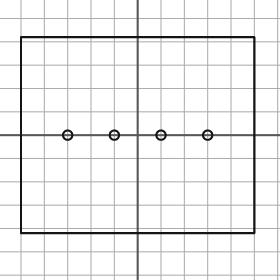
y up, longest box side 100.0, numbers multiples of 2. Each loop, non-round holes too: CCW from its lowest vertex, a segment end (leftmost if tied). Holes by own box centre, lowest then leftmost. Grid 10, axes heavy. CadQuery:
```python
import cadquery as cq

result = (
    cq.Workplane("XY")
    .moveTo(-50.0, -42.0)
    .lineTo(50.0, -42.0)
    .lineTo(50.0, 42.0)
    .lineTo(-50.0, 42.0)
    .close()
    .moveTo(-30.0, 0.0)
    .circle(2.0)
    .moveTo(-10.0, 0.0)
    .circle(2.0)
    .moveTo(10.0, 0.0)
    .circle(2.0)
    .moveTo(30.0, 0.0)
    .circle(2.0)
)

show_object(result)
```